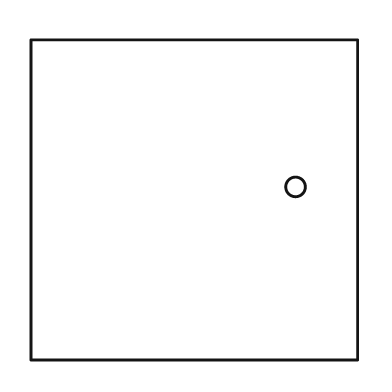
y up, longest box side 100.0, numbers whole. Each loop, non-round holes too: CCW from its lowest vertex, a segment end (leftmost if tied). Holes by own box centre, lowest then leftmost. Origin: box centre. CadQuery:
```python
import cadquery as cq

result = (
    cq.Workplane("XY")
    .moveTo(-50.0, -49.0)
    .lineTo(50.0, -49.0)
    .lineTo(50.0, 49.0)
    .lineTo(-50.0, 49.0)
    .close()
    .moveTo(31.0, 4.0)
    .circle(3.0)
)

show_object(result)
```